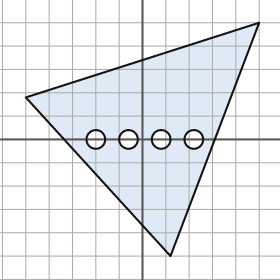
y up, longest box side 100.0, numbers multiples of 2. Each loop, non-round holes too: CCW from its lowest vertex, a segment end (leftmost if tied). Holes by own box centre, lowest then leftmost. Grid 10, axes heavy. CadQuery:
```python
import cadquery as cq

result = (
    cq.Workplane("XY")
    .moveTo(12.0, -50.0)
    .lineTo(50.0, 50.0)
    .lineTo(-50.0, 18.0)
    .close()
    .moveTo(-20.0, 0.0)
    .circle(4.0)
    .moveTo(-6.0, 0.0)
    .circle(4.0)
    .moveTo(8.0, 0.0)
    .circle(4.0)
    .moveTo(22.0, 0.0)
    .circle(4.0)
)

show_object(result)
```